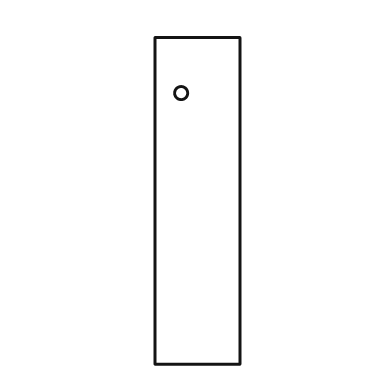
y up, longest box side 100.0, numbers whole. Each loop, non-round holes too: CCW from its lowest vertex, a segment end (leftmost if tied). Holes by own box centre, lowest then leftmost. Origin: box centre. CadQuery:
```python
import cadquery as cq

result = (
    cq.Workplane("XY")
    .moveTo(-13.0, -50.0)
    .lineTo(13.0, -50.0)
    .lineTo(13.0, 50.0)
    .lineTo(-13.0, 50.0)
    .close()
    .moveTo(-5.0, 33.0)
    .circle(2.0)
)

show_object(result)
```